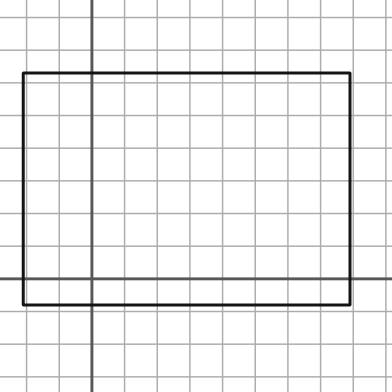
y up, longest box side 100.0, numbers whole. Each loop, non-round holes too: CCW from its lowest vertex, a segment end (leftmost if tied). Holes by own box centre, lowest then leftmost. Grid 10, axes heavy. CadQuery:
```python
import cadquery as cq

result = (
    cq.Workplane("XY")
    .moveTo(-21.0, -8.0)
    .lineTo(79.0, -8.0)
    .lineTo(79.0, 63.0)
    .lineTo(-21.0, 63.0)
    .close()
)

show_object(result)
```